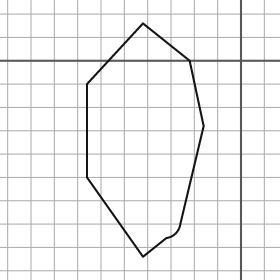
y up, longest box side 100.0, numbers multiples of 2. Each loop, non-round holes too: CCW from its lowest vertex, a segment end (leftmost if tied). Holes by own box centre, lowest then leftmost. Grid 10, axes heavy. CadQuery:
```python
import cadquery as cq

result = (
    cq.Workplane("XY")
    .moveTo(-42.0, -84.0)
    .lineTo(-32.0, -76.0)
    .threePointArc((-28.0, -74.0), (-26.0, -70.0))
    .lineTo(-16.0, -28.0)
    .lineTo(-22.0, 0.0)
    .lineTo(-42.0, 16.0)
    .lineTo(-66.0, -10.0)
    .lineTo(-66.0, -50.0)
    .close()
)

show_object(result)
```